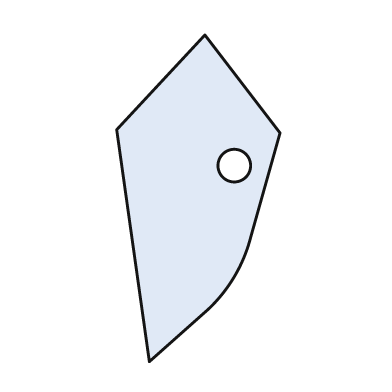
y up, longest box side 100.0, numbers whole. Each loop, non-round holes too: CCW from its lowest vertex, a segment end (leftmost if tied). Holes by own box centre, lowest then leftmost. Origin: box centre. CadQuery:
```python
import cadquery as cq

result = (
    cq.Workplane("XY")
    .moveTo(-15.0, -50.0)
    .lineTo(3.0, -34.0)
    .threePointArc((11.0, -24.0), (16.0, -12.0))
    .lineTo(25.0, 20.0)
    .lineTo(2.0, 50.0)
    .lineTo(-25.0, 21.0)
    .close()
    .moveTo(11.0, 10.0)
    .circle(5.0)
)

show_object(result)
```